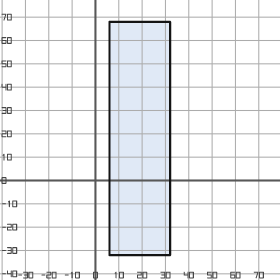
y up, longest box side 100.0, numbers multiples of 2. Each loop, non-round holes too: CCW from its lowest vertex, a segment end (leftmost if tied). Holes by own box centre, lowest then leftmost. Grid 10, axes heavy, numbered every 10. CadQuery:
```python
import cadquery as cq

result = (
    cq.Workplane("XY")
    .moveTo(6.0, -32.0)
    .lineTo(32.0, -32.0)
    .lineTo(32.0, 68.0)
    .lineTo(6.0, 68.0)
    .close()
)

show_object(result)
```